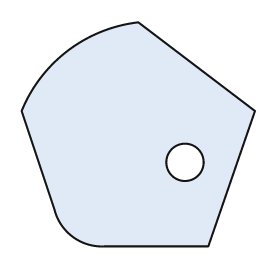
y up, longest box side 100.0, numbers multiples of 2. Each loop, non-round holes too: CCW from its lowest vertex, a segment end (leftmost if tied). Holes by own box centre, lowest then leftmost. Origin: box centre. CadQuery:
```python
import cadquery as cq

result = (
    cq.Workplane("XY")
    .moveTo(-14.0, -48.0)
    .lineTo(30.0, -48.0)
    .lineTo(50.0, 10.0)
    .lineTo(0.0, 48.0)
    .threePointArc((-30.0, 36.0), (-50.0, 10.0))
    .lineTo(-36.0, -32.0)
    .threePointArc((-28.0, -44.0), (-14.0, -48.0))
    .close()
    .moveTo(20.0, -12.0)
    .circle(8.0)
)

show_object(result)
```